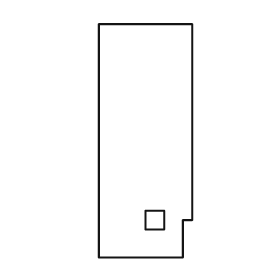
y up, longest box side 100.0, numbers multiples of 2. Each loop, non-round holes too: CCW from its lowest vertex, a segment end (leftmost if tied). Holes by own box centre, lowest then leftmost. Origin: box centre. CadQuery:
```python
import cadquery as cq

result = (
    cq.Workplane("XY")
    .moveTo(-20.0, -50.0)
    .lineTo(16.0, -50.0)
    .lineTo(16.0, -34.0)
    .lineTo(20.0, -34.0)
    .lineTo(20.0, 50.0)
    .lineTo(-20.0, 50.0)
    .close()
    .moveTo(0.0, -38.0)
    .lineTo(8.0, -38.0)
    .lineTo(8.0, -30.0)
    .lineTo(0.0, -30.0)
    .close()
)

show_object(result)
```